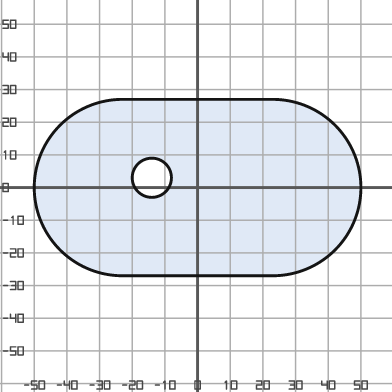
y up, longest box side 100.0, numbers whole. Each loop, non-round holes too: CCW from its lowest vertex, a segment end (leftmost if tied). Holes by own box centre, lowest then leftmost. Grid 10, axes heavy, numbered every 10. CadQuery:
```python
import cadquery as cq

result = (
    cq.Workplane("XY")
    .moveTo(-23.0, -27.0)
    .lineTo(23.0, -27.0)
    .threePointArc((50.0, 0.0), (23.0, 27.0))
    .lineTo(-23.0, 27.0)
    .threePointArc((-50.0, 0.0), (-23.0, -27.0))
    .close()
    .moveTo(-14.0, 3.0)
    .circle(6.0)
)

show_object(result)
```